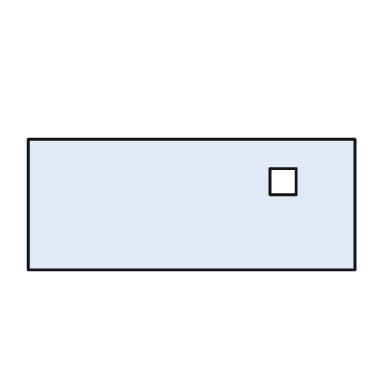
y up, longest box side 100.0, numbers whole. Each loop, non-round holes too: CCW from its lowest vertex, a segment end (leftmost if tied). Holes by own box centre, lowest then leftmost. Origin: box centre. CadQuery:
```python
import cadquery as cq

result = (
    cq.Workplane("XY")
    .moveTo(-50.0, -20.0)
    .lineTo(50.0, -20.0)
    .lineTo(50.0, 20.0)
    .lineTo(-50.0, 20.0)
    .close()
    .moveTo(24.0, 3.0)
    .lineTo(32.0, 3.0)
    .lineTo(32.0, 11.0)
    .lineTo(24.0, 11.0)
    .close()
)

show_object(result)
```